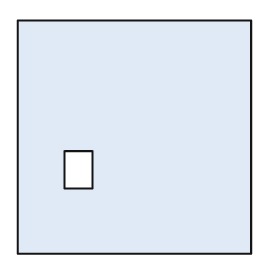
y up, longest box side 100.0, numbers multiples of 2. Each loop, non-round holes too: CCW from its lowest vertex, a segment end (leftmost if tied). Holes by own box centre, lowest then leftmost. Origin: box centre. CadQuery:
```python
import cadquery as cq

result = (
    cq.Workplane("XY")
    .moveTo(-50.0, -50.0)
    .lineTo(50.0, -50.0)
    .lineTo(50.0, 50.0)
    .lineTo(-50.0, 50.0)
    .close()
    .moveTo(-30.0, -22.0)
    .lineTo(-18.0, -22.0)
    .lineTo(-18.0, -6.0)
    .lineTo(-30.0, -6.0)
    .close()
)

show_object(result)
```